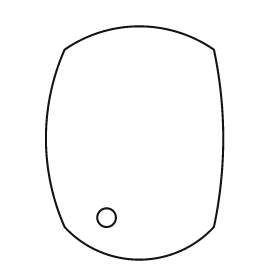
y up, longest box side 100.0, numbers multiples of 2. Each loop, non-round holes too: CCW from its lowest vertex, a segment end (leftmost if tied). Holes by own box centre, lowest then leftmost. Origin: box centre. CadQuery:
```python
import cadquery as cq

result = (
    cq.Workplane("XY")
    .moveTo(-30.0, -36.0)
    .threePointArc((2.0, -50.0), (34.0, -36.0))
    .threePointArc((38.0, 2.0), (34.0, 40.0))
    .threePointArc((2.0, 50.0), (-30.0, 40.0))
    .threePointArc((-38.0, 2.0), (-30.0, -36.0))
    .close()
    .moveTo(-12.0, -32.0)
    .circle(4.0)
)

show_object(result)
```